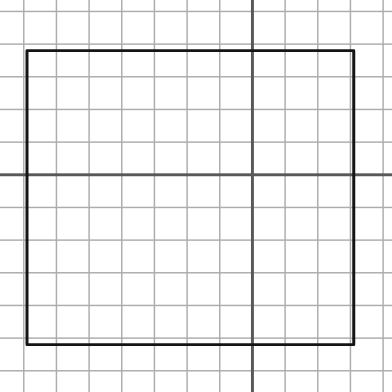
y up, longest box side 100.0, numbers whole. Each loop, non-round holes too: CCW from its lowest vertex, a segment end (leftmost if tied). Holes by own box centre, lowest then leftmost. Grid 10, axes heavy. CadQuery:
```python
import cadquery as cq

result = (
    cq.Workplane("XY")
    .moveTo(-69.0, -52.0)
    .lineTo(31.0, -52.0)
    .lineTo(31.0, 38.0)
    .lineTo(-69.0, 38.0)
    .close()
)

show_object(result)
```